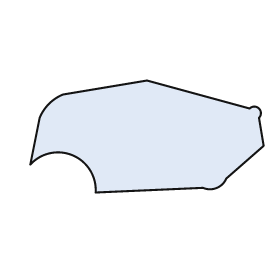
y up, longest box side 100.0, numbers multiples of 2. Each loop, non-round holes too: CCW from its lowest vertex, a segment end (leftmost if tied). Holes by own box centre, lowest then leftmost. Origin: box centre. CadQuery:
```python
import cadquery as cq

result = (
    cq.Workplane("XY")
    .moveTo(-22.0, -24.0)
    .lineTo(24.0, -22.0)
    .threePointArc((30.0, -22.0), (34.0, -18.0))
    .lineTo(50.0, -4.0)
    .lineTo(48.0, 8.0)
    .threePointArc((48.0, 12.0), (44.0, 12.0))
    .lineTo(0.0, 24.0)
    .lineTo(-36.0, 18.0)
    .threePointArc((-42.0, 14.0), (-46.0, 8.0))
    .lineTo(-50.0, -12.0)
    .threePointArc((-32.0, -8.0), (-22.0, -24.0))
    .close()
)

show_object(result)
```